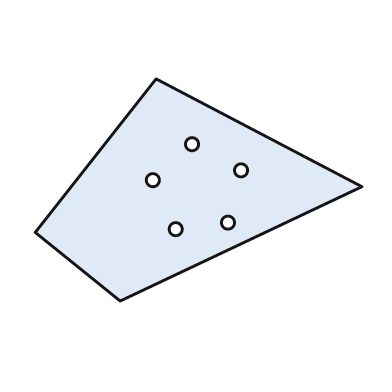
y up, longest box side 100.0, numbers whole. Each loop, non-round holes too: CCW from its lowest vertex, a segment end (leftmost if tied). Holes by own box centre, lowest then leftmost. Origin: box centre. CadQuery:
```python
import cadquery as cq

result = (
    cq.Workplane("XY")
    .moveTo(-24.0, -34.0)
    .lineTo(50.0, 1.0)
    .lineTo(-13.0, 34.0)
    .lineTo(-50.0, -13.0)
    .close()
    .moveTo(-7.0, -12.0)
    .circle(2.0)
    .moveTo(9.0, -10.0)
    .circle(2.0)
    .moveTo(-14.0, 3.0)
    .circle(2.0)
    .moveTo(13.0, 6.0)
    .circle(2.0)
    .moveTo(-2.0, 14.0)
    .circle(2.0)
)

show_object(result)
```